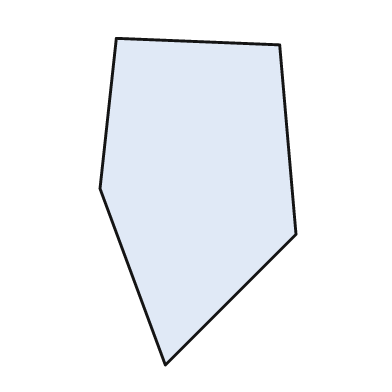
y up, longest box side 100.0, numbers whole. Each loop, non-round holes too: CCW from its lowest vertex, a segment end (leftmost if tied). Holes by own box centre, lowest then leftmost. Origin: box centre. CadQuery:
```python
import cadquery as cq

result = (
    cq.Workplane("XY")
    .moveTo(-10.0, -50.0)
    .lineTo(30.0, -10.0)
    .lineTo(25.0, 48.0)
    .lineTo(-25.0, 50.0)
    .lineTo(-30.0, 4.0)
    .close()
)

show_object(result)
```